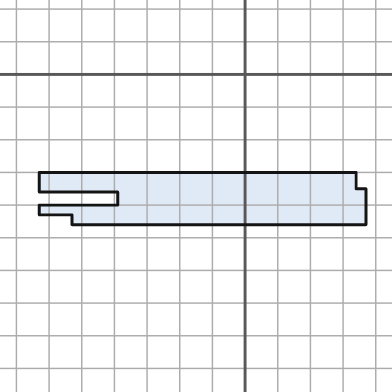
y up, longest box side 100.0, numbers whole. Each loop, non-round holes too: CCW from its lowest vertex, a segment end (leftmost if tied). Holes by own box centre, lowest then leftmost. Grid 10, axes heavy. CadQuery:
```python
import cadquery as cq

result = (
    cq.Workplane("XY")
    .moveTo(-53.0, -46.0)
    .lineTo(37.0, -46.0)
    .lineTo(37.0, -35.0)
    .lineTo(34.0, -35.0)
    .lineTo(34.0, -30.0)
    .lineTo(-63.0, -30.0)
    .lineTo(-63.0, -36.0)
    .lineTo(-39.0, -36.0)
    .lineTo(-39.0, -40.0)
    .lineTo(-63.0, -40.0)
    .lineTo(-63.0, -43.0)
    .lineTo(-53.0, -43.0)
    .close()
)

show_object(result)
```